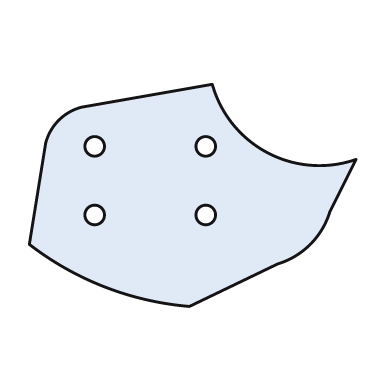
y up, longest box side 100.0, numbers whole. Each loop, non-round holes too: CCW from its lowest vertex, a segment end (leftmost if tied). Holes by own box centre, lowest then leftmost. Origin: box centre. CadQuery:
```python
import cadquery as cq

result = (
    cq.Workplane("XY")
    .moveTo(-1.0, -34.0)
    .lineTo(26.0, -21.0)
    .threePointArc((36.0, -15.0), (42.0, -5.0))
    .lineTo(50.0, 11.0)
    .threePointArc((23.0, 13.0), (6.0, 34.0))
    .lineTo(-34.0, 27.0)
    .threePointArc((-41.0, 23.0), (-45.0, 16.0))
    .lineTo(-50.0, -15.0)
    .threePointArc((-27.0, -28.0), (-1.0, -34.0))
    .close()
    .moveTo(-30.0, -6.0)
    .circle(3.0)
    .moveTo(4.0, -6.0)
    .circle(3.0)
    .moveTo(-30.0, 15.0)
    .circle(3.0)
    .moveTo(4.0, 15.0)
    .circle(3.0)
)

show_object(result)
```